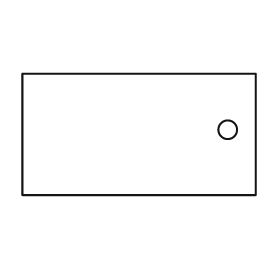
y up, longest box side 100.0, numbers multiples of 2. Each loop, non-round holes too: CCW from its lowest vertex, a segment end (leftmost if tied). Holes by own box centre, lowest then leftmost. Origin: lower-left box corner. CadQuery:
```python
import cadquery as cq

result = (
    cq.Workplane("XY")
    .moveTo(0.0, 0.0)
    .lineTo(100.0, 0.0)
    .lineTo(100.0, 52.0)
    .lineTo(0.0, 52.0)
    .close()
    .moveTo(88.0, 28.0)
    .circle(4.0)
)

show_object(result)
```